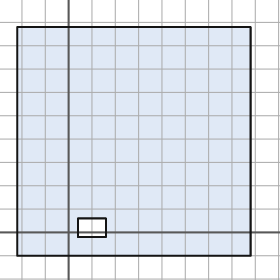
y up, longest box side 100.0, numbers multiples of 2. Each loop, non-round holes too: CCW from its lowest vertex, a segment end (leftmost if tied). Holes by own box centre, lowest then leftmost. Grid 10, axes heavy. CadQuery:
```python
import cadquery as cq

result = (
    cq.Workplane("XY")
    .moveTo(-22.0, -10.0)
    .lineTo(78.0, -10.0)
    .lineTo(78.0, 88.0)
    .lineTo(-22.0, 88.0)
    .close()
    .moveTo(4.0, -2.0)
    .lineTo(16.0, -2.0)
    .lineTo(16.0, 6.0)
    .lineTo(4.0, 6.0)
    .close()
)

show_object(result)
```